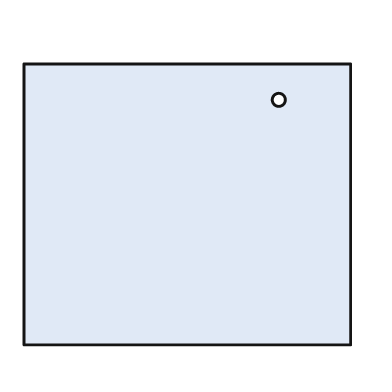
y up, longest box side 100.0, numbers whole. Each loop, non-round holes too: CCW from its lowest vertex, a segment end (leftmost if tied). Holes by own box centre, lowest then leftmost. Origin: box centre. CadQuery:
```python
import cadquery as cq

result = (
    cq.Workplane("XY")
    .moveTo(-50.0, -43.0)
    .lineTo(50.0, -43.0)
    .lineTo(50.0, 43.0)
    .lineTo(-50.0, 43.0)
    .close()
    .moveTo(28.0, 32.0)
    .circle(2.0)
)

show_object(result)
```